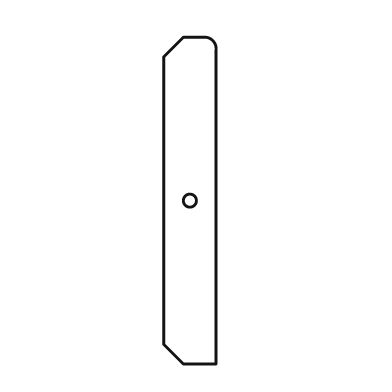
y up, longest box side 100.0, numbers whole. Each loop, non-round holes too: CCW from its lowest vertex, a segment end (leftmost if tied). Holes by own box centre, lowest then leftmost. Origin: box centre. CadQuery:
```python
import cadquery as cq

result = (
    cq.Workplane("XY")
    .moveTo(-2.0, -50.0)
    .lineTo(8.0, -50.0)
    .lineTo(8.0, 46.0)
    .threePointArc((7.0, 49.0), (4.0, 50.0))
    .lineTo(-2.0, 50.0)
    .lineTo(-8.0, 44.0)
    .lineTo(-8.0, -44.0)
    .close()
    .moveTo(0.0, 0.0)
    .circle(2.0)
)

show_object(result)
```